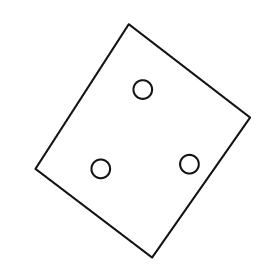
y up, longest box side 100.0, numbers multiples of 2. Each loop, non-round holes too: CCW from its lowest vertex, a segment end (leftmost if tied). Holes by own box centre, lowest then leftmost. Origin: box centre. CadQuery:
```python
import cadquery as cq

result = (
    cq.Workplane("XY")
    .moveTo(4.0, -50.0)
    .lineTo(46.0, 10.0)
    .lineTo(-6.0, 50.0)
    .lineTo(-46.0, -12.0)
    .close()
    .moveTo(-18.0, -12.0)
    .circle(4.0)
    .moveTo(20.0, -10.0)
    .circle(4.0)
    .moveTo(0.0, 22.0)
    .circle(4.0)
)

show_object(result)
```